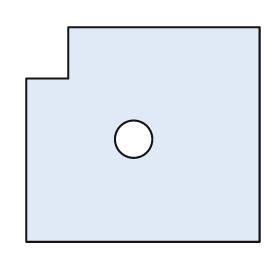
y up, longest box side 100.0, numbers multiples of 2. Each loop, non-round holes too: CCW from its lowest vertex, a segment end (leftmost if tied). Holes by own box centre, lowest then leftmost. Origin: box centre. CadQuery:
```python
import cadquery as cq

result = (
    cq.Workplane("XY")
    .moveTo(-50.0, -46.0)
    .lineTo(50.0, -46.0)
    .lineTo(50.0, 46.0)
    .lineTo(-32.0, 46.0)
    .lineTo(-32.0, 24.0)
    .lineTo(-50.0, 24.0)
    .close()
    .moveTo(-4.0, -2.0)
    .circle(8.0)
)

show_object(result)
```